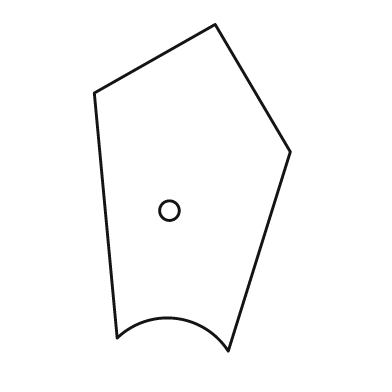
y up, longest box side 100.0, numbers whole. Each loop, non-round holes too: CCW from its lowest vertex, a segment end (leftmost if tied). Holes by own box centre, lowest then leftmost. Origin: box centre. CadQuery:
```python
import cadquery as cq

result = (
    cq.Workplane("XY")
    .moveTo(11.0, -50.0)
    .lineTo(30.0, 11.0)
    .lineTo(7.0, 50.0)
    .lineTo(-30.0, 29.0)
    .lineTo(-23.0, -46.0)
    .threePointArc((-5.0, -40.0), (11.0, -50.0))
    .close()
    .moveTo(-7.0, -7.0)
    .circle(3.0)
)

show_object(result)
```